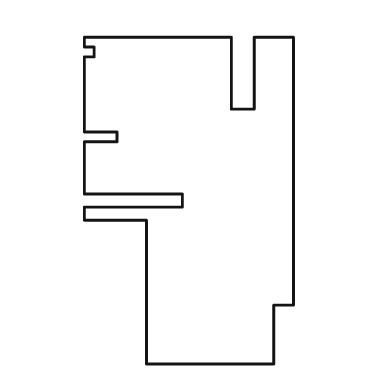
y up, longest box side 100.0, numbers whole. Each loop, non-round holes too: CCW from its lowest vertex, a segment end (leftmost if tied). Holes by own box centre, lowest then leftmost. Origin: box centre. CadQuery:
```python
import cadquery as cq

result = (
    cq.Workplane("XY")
    .moveTo(-13.0, -50.0)
    .lineTo(26.0, -50.0)
    .lineTo(26.0, -32.0)
    .lineTo(32.0, -32.0)
    .lineTo(32.0, 50.0)
    .lineTo(20.0, 50.0)
    .lineTo(20.0, 28.0)
    .lineTo(13.0, 28.0)
    .lineTo(13.0, 50.0)
    .lineTo(-32.0, 50.0)
    .lineTo(-32.0, 47.0)
    .lineTo(-29.0, 47.0)
    .lineTo(-29.0, 44.0)
    .lineTo(-32.0, 44.0)
    .lineTo(-32.0, 21.0)
    .lineTo(-22.0, 21.0)
    .lineTo(-22.0, 18.0)
    .lineTo(-32.0, 18.0)
    .lineTo(-32.0, 2.0)
    .lineTo(-2.0, 2.0)
    .lineTo(-2.0, -2.0)
    .lineTo(-32.0, -2.0)
    .lineTo(-32.0, -6.0)
    .lineTo(-13.0, -6.0)
    .close()
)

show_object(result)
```